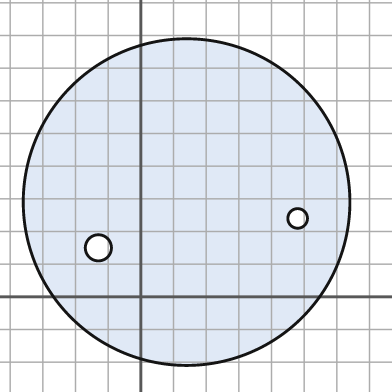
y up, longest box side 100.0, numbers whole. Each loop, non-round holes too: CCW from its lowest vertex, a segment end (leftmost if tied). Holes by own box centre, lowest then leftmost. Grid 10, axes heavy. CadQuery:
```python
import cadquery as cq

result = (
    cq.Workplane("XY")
    .moveTo(14.0, 29.0)
    .circle(50.0)
    .moveTo(-13.0, 15.0)
    .circle(4.0)
    .moveTo(48.0, 24.0)
    .circle(3.0)
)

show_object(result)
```